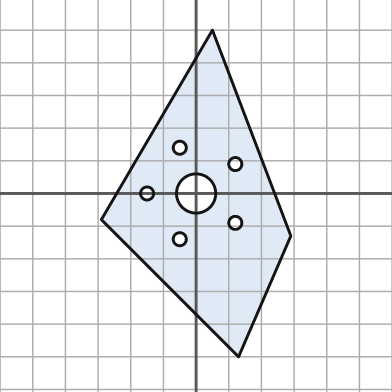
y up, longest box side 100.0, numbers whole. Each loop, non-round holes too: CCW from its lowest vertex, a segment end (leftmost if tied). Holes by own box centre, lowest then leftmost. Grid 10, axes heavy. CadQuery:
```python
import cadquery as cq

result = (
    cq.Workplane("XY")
    .moveTo(13.0, -50.0)
    .lineTo(29.0, -13.0)
    .lineTo(5.0, 50.0)
    .lineTo(-29.0, -8.0)
    .close()
    .moveTo(-5.0, -14.0)
    .circle(2.0)
    .moveTo(12.0, -9.0)
    .circle(2.0)
    .moveTo(-15.0, 0.0)
    .circle(2.0)
    .moveTo(0.0, 0.0)
    .circle(6.0)
    .moveTo(12.0, 9.0)
    .circle(2.0)
    .moveTo(-5.0, 14.0)
    .circle(2.0)
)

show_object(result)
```